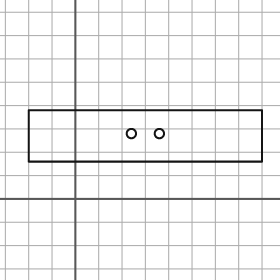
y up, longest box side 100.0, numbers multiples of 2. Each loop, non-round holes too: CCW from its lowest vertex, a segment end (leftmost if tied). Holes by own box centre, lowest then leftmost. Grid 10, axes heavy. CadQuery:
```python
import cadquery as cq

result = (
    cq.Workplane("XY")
    .moveTo(-20.0, 16.0)
    .lineTo(80.0, 16.0)
    .lineTo(80.0, 38.0)
    .lineTo(-20.0, 38.0)
    .close()
    .moveTo(24.0, 28.0)
    .circle(2.0)
    .moveTo(36.0, 28.0)
    .circle(2.0)
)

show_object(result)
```